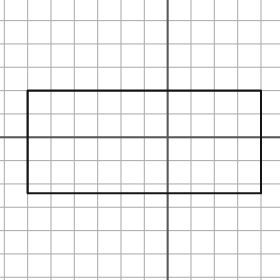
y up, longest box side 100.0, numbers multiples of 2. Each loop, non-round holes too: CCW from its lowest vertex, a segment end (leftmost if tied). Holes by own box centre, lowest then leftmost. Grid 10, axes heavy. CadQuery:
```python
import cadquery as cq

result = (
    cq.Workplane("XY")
    .moveTo(-60.0, -24.0)
    .lineTo(40.0, -24.0)
    .lineTo(40.0, 20.0)
    .lineTo(-60.0, 20.0)
    .close()
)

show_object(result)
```